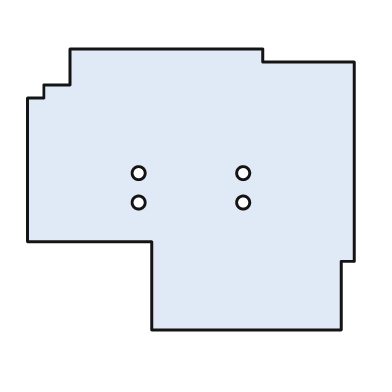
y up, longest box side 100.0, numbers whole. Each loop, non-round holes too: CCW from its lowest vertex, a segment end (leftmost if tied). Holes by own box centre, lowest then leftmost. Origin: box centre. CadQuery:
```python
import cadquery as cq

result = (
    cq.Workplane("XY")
    .moveTo(-12.0, -43.0)
    .lineTo(46.0, -43.0)
    .lineTo(46.0, -22.0)
    .lineTo(50.0, -22.0)
    .lineTo(50.0, 39.0)
    .lineTo(22.0, 39.0)
    .lineTo(22.0, 43.0)
    .lineTo(-37.0, 43.0)
    .lineTo(-37.0, 32.0)
    .lineTo(-45.0, 32.0)
    .lineTo(-45.0, 28.0)
    .lineTo(-50.0, 28.0)
    .lineTo(-50.0, -16.0)
    .lineTo(-12.0, -16.0)
    .close()
    .moveTo(-16.0, -4.0)
    .circle(2.0)
    .moveTo(16.0, -4.0)
    .circle(2.0)
    .moveTo(-16.0, 5.0)
    .circle(2.0)
    .moveTo(16.0, 5.0)
    .circle(2.0)
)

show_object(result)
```